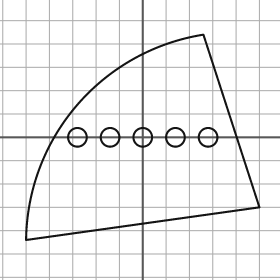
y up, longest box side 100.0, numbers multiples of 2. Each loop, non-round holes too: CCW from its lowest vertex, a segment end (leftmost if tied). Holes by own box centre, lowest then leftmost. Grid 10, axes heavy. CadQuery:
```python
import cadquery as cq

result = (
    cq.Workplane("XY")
    .moveTo(-50.0, -44.0)
    .lineTo(50.0, -30.0)
    .lineTo(26.0, 44.0)
    .threePointArc((-28.0, 14.0), (-50.0, -44.0))
    .close()
    .moveTo(-28.0, 0.0)
    .circle(4.0)
    .moveTo(-14.0, 0.0)
    .circle(4.0)
    .moveTo(0.0, 0.0)
    .circle(4.0)
    .moveTo(14.0, 0.0)
    .circle(4.0)
    .moveTo(28.0, 0.0)
    .circle(4.0)
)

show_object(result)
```